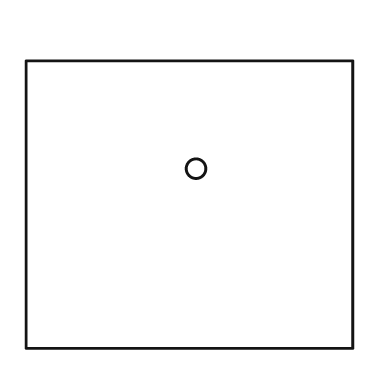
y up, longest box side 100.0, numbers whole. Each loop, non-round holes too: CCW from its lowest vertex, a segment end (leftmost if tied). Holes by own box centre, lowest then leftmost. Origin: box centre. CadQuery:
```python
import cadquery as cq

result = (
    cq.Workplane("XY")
    .moveTo(-50.0, -44.0)
    .lineTo(50.0, -44.0)
    .lineTo(50.0, 44.0)
    .lineTo(-50.0, 44.0)
    .close()
    .moveTo(2.0, 11.0)
    .circle(3.0)
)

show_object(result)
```